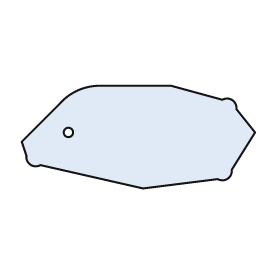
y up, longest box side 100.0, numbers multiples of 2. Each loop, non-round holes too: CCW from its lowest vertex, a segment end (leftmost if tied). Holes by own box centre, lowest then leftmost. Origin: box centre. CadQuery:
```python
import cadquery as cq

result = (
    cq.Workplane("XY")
    .moveTo(2.0, -22.0)
    .lineTo(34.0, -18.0)
    .threePointArc((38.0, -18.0), (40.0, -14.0))
    .lineTo(50.0, 2.0)
    .lineTo(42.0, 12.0)
    .threePointArc((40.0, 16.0), (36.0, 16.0))
    .lineTo(14.0, 22.0)
    .lineTo(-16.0, 22.0)
    .threePointArc((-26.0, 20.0), (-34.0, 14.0))
    .lineTo(-50.0, -2.0)
    .lineTo(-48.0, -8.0)
    .threePointArc((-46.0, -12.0), (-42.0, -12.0))
    .close()
    .moveTo(-30.0, 2.0)
    .circle(2.0)
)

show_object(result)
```